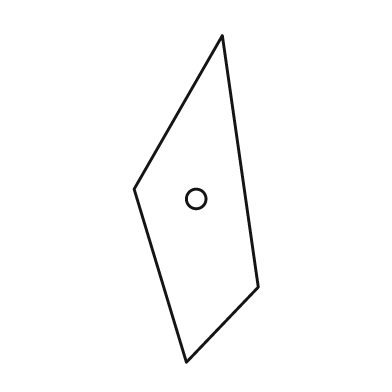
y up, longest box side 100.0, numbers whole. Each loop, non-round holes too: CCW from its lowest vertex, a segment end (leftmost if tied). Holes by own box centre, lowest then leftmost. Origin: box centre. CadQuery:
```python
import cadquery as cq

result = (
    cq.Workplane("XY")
    .moveTo(-3.0, -50.0)
    .lineTo(19.0, -27.0)
    .lineTo(8.0, 50.0)
    .lineTo(-19.0, 3.0)
    .close()
    .moveTo(0.0, 0.0)
    .circle(3.0)
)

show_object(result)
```